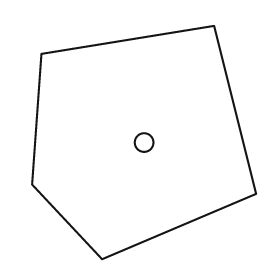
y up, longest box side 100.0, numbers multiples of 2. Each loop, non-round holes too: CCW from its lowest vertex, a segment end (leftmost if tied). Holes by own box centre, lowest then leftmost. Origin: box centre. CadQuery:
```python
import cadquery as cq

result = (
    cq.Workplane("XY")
    .moveTo(-18.0, -50.0)
    .lineTo(48.0, -22.0)
    .lineTo(30.0, 50.0)
    .lineTo(-44.0, 38.0)
    .lineTo(-48.0, -18.0)
    .close()
    .moveTo(0.0, 0.0)
    .circle(4.0)
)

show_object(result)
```